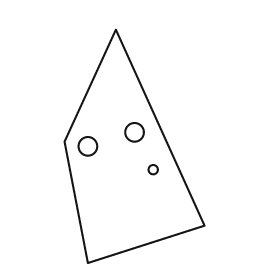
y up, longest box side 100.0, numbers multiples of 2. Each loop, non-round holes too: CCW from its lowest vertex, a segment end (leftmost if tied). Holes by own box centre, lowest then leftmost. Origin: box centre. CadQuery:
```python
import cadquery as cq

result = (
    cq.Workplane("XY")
    .moveTo(-20.0, -50.0)
    .lineTo(30.0, -34.0)
    .lineTo(-8.0, 50.0)
    .lineTo(-30.0, 2.0)
    .close()
    .moveTo(8.0, -10.0)
    .circle(2.0)
    .moveTo(-20.0, 0.0)
    .circle(4.0)
    .moveTo(0.0, 6.0)
    .circle(4.0)
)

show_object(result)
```